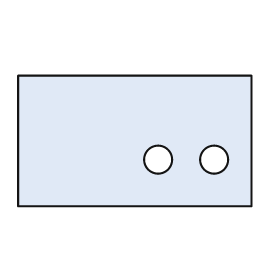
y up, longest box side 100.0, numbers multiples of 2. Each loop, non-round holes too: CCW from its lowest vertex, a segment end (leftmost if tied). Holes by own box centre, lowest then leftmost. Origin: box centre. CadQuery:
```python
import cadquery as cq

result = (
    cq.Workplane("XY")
    .moveTo(-50.0, -28.0)
    .lineTo(50.0, -28.0)
    .lineTo(50.0, 28.0)
    .lineTo(-50.0, 28.0)
    .close()
    .moveTo(10.0, -8.0)
    .circle(6.0)
    .moveTo(34.0, -8.0)
    .circle(6.0)
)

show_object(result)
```